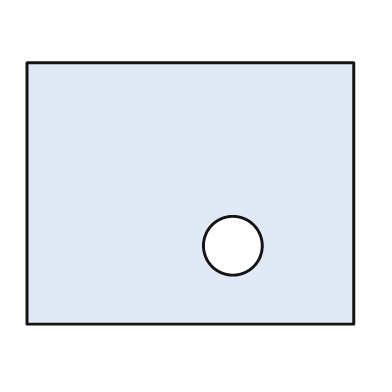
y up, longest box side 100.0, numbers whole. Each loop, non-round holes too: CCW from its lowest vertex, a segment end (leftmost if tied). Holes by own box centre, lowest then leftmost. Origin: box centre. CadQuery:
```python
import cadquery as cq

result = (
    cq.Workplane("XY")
    .moveTo(-50.0, -40.0)
    .lineTo(50.0, -40.0)
    .lineTo(50.0, 40.0)
    .lineTo(-50.0, 40.0)
    .close()
    .moveTo(13.0, -16.0)
    .circle(9.0)
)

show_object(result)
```